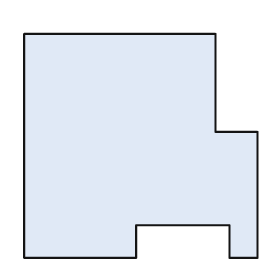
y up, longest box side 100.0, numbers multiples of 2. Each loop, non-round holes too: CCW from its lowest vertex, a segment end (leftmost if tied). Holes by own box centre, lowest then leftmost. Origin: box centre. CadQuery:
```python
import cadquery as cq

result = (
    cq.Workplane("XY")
    .moveTo(-50.0, -48.0)
    .lineTo(-2.0, -48.0)
    .lineTo(-2.0, -34.0)
    .lineTo(38.0, -34.0)
    .lineTo(38.0, -48.0)
    .lineTo(50.0, -48.0)
    .lineTo(50.0, 6.0)
    .lineTo(32.0, 6.0)
    .lineTo(32.0, 48.0)
    .lineTo(-50.0, 48.0)
    .close()
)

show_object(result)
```